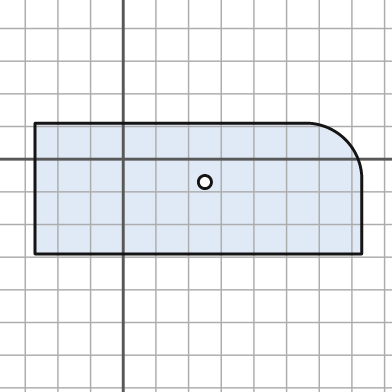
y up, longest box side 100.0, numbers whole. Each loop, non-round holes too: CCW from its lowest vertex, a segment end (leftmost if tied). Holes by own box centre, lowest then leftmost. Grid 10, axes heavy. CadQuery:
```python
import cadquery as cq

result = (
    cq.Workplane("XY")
    .moveTo(-27.0, -29.0)
    .lineTo(73.0, -29.0)
    .lineTo(73.0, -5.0)
    .threePointArc((68.0, 6.0), (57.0, 11.0))
    .lineTo(-27.0, 11.0)
    .close()
    .moveTo(25.0, -7.0)
    .circle(2.0)
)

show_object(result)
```